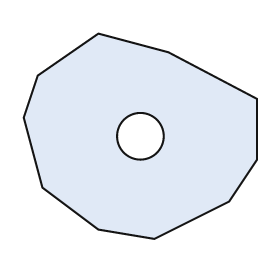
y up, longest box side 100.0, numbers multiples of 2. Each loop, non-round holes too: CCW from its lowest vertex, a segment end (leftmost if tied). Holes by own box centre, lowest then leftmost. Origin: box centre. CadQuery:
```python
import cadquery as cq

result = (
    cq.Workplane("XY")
    .moveTo(6.0, -44.0)
    .lineTo(38.0, -28.0)
    .lineTo(50.0, -10.0)
    .lineTo(50.0, 16.0)
    .lineTo(12.0, 36.0)
    .lineTo(-18.0, 44.0)
    .lineTo(-44.0, 26.0)
    .lineTo(-50.0, 8.0)
    .lineTo(-42.0, -22.0)
    .lineTo(-18.0, -40.0)
    .close()
    .moveTo(0.0, 0.0)
    .circle(10.0)
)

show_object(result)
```